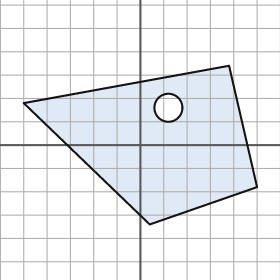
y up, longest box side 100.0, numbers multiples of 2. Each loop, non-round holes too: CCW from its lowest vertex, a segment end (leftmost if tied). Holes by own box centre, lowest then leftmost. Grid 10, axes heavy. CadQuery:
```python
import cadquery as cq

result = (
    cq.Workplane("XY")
    .moveTo(4.0, -34.0)
    .lineTo(50.0, -18.0)
    .lineTo(38.0, 34.0)
    .lineTo(-50.0, 18.0)
    .close()
    .moveTo(12.0, 16.0)
    .circle(6.0)
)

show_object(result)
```